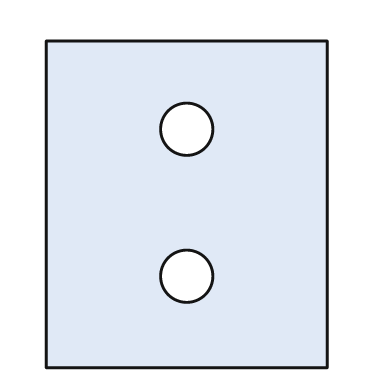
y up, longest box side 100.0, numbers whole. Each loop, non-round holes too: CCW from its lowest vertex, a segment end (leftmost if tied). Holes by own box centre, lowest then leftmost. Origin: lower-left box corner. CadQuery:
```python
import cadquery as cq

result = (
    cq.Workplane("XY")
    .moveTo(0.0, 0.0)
    .lineTo(86.0, 0.0)
    .lineTo(86.0, 100.0)
    .lineTo(0.0, 100.0)
    .close()
    .moveTo(43.0, 28.0)
    .circle(8.0)
    .moveTo(43.0, 73.0)
    .circle(8.0)
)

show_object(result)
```